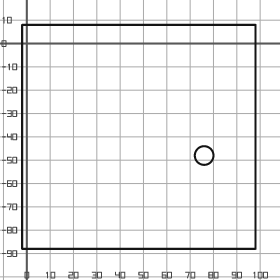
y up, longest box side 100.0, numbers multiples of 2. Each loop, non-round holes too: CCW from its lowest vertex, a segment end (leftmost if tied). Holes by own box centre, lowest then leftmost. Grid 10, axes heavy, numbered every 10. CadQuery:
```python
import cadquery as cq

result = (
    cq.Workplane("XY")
    .moveTo(-2.0, -88.0)
    .lineTo(98.0, -88.0)
    .lineTo(98.0, 8.0)
    .lineTo(-2.0, 8.0)
    .close()
    .moveTo(76.0, -48.0)
    .circle(4.0)
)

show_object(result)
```